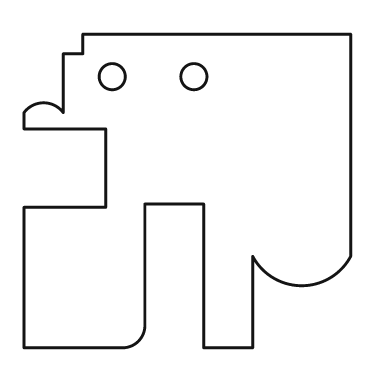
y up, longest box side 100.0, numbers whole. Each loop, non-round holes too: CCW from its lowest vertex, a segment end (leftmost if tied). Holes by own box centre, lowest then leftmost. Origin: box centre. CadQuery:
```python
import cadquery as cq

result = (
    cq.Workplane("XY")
    .moveTo(-50.0, -48.0)
    .lineTo(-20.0, -48.0)
    .threePointArc((-15.0, -46.0), (-13.0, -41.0))
    .lineTo(-13.0, -4.0)
    .lineTo(5.0, -4.0)
    .lineTo(5.0, -48.0)
    .lineTo(20.0, -48.0)
    .lineTo(20.0, -20.0)
    .threePointArc((35.0, -29.0), (50.0, -20.0))
    .lineTo(50.0, 48.0)
    .lineTo(-32.0, 48.0)
    .lineTo(-32.0, 42.0)
    .lineTo(-38.0, 42.0)
    .lineTo(-38.0, 24.0)
    .threePointArc((-44.0, 27.0), (-50.0, 24.0))
    .lineTo(-50.0, 19.0)
    .lineTo(-25.0, 19.0)
    .lineTo(-25.0, -5.0)
    .lineTo(-50.0, -5.0)
    .close()
    .moveTo(-23.0, 35.0)
    .circle(4.0)
    .moveTo(2.0, 35.0)
    .circle(4.0)
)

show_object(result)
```